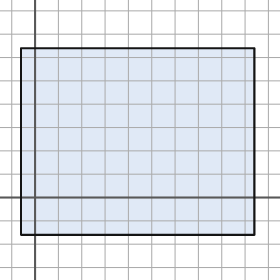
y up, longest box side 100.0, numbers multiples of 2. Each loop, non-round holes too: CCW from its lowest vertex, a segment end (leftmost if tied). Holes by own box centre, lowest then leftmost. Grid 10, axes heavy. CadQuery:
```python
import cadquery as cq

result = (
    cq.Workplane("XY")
    .moveTo(-6.0, -16.0)
    .lineTo(94.0, -16.0)
    .lineTo(94.0, 64.0)
    .lineTo(-6.0, 64.0)
    .close()
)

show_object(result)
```